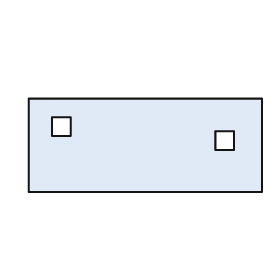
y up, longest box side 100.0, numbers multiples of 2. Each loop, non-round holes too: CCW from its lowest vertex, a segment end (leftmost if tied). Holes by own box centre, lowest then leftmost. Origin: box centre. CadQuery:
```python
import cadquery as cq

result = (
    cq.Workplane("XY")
    .moveTo(-50.0, -20.0)
    .lineTo(50.0, -20.0)
    .lineTo(50.0, 20.0)
    .lineTo(-50.0, 20.0)
    .close()
    .moveTo(30.0, -2.0)
    .lineTo(38.0, -2.0)
    .lineTo(38.0, 6.0)
    .lineTo(30.0, 6.0)
    .close()
    .moveTo(-40.0, 4.0)
    .lineTo(-32.0, 4.0)
    .lineTo(-32.0, 12.0)
    .lineTo(-40.0, 12.0)
    .close()
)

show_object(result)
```